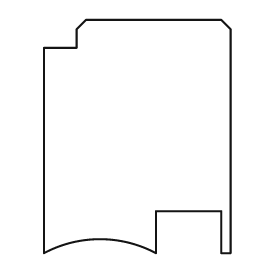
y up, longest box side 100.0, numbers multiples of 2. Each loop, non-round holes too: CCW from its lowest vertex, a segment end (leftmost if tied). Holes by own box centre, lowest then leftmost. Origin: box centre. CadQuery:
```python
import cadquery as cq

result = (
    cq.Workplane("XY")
    .moveTo(-40.0, -50.0)
    .threePointArc((-16.0, -44.0), (8.0, -50.0))
    .lineTo(8.0, -32.0)
    .lineTo(36.0, -32.0)
    .lineTo(36.0, -50.0)
    .lineTo(40.0, -50.0)
    .lineTo(40.0, 46.0)
    .lineTo(36.0, 50.0)
    .lineTo(-22.0, 50.0)
    .lineTo(-26.0, 46.0)
    .lineTo(-26.0, 38.0)
    .lineTo(-40.0, 38.0)
    .close()
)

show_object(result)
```